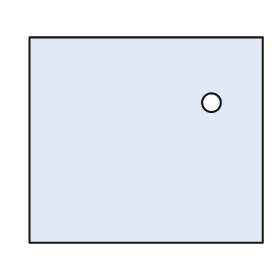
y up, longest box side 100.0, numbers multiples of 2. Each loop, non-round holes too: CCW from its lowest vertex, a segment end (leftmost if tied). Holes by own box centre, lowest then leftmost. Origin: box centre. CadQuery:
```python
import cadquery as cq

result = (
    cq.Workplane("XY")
    .moveTo(-50.0, -44.0)
    .lineTo(50.0, -44.0)
    .lineTo(50.0, 44.0)
    .lineTo(-50.0, 44.0)
    .close()
    .moveTo(28.0, 16.0)
    .circle(4.0)
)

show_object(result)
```